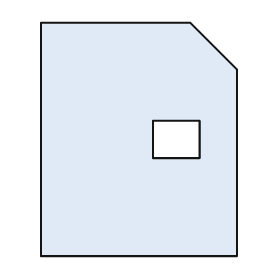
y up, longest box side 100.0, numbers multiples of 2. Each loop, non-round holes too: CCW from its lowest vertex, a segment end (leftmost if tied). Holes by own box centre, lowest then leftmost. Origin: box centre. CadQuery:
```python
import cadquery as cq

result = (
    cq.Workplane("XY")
    .moveTo(-42.0, -50.0)
    .lineTo(42.0, -50.0)
    .lineTo(42.0, 30.0)
    .lineTo(22.0, 50.0)
    .lineTo(-42.0, 50.0)
    .close()
    .moveTo(6.0, -8.0)
    .lineTo(26.0, -8.0)
    .lineTo(26.0, 8.0)
    .lineTo(6.0, 8.0)
    .close()
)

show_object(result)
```